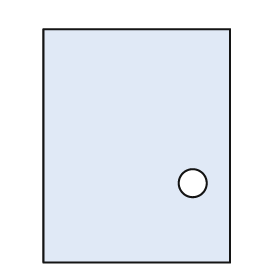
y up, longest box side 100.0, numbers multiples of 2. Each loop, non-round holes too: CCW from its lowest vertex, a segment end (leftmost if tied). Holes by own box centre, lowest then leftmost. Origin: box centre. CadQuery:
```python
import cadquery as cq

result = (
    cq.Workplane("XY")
    .moveTo(-40.0, -50.0)
    .lineTo(40.0, -50.0)
    .lineTo(40.0, 50.0)
    .lineTo(-40.0, 50.0)
    .close()
    .moveTo(24.0, -16.0)
    .circle(6.0)
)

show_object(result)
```